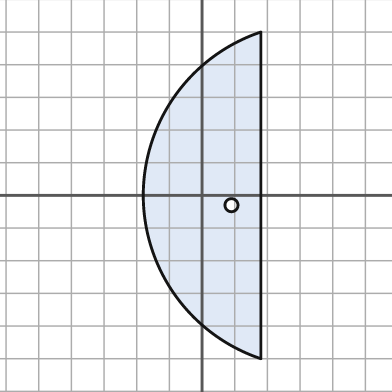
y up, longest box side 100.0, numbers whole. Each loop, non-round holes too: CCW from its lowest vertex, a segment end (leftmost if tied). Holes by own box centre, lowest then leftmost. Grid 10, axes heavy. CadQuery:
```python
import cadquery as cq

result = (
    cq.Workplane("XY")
    .moveTo(18.0, -50.0)
    .lineTo(18.0, 50.0)
    .threePointArc((-18.0, 0.0), (18.0, -50.0))
    .close()
    .moveTo(9.0, -3.0)
    .circle(2.0)
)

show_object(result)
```